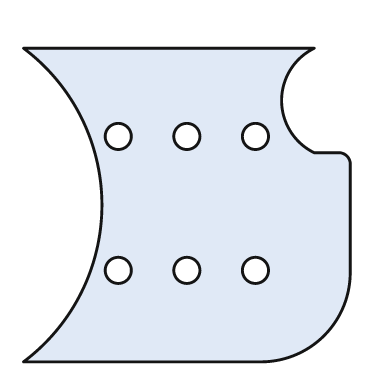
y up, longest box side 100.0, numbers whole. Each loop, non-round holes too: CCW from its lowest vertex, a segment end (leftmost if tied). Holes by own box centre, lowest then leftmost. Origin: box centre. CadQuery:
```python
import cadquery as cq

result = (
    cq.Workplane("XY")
    .moveTo(-50.0, -48.0)
    .lineTo(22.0, -48.0)
    .threePointArc((42.0, -40.0), (50.0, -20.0))
    .lineTo(50.0, 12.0)
    .threePointArc((49.0, 15.0), (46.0, 16.0))
    .lineTo(39.0, 16.0)
    .threePointArc((29.0, 32.0), (39.0, 48.0))
    .lineTo(-50.0, 48.0)
    .threePointArc((-26.0, 0.0), (-50.0, -48.0))
    .close()
    .moveTo(-21.0, -20.0)
    .circle(4.0)
    .moveTo(0.0, -20.0)
    .circle(4.0)
    .moveTo(21.0, -20.0)
    .circle(4.0)
    .moveTo(-21.0, 21.0)
    .circle(4.0)
    .moveTo(0.0, 21.0)
    .circle(4.0)
    .moveTo(21.0, 21.0)
    .circle(4.0)
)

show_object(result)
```